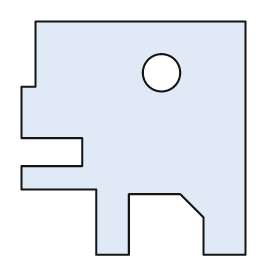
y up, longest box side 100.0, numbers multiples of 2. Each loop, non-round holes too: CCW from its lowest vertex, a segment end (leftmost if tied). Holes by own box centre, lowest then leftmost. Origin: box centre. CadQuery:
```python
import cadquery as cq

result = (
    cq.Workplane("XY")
    .moveTo(-16.0, -50.0)
    .lineTo(-2.0, -50.0)
    .lineTo(-2.0, -24.0)
    .lineTo(20.0, -24.0)
    .lineTo(30.0, -34.0)
    .lineTo(30.0, -50.0)
    .lineTo(48.0, -50.0)
    .lineTo(48.0, 50.0)
    .lineTo(-42.0, 50.0)
    .lineTo(-42.0, 22.0)
    .lineTo(-48.0, 22.0)
    .lineTo(-48.0, 0.0)
    .lineTo(-22.0, 0.0)
    .lineTo(-22.0, -12.0)
    .lineTo(-48.0, -12.0)
    .lineTo(-48.0, -22.0)
    .lineTo(-16.0, -22.0)
    .close()
    .moveTo(12.0, 28.0)
    .circle(8.0)
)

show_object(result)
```